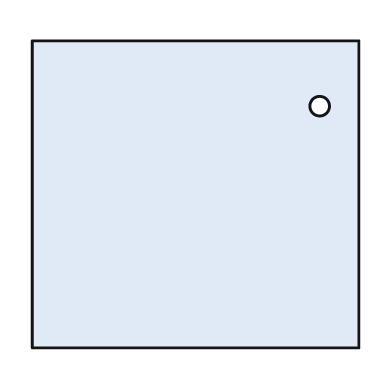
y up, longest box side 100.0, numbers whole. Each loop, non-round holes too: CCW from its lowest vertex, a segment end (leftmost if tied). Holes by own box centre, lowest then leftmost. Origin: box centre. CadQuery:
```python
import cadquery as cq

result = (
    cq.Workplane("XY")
    .moveTo(-50.0, -47.0)
    .lineTo(50.0, -47.0)
    .lineTo(50.0, 47.0)
    .lineTo(-50.0, 47.0)
    .close()
    .moveTo(38.0, 27.0)
    .circle(3.0)
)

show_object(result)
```